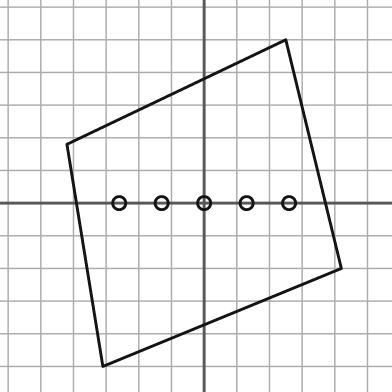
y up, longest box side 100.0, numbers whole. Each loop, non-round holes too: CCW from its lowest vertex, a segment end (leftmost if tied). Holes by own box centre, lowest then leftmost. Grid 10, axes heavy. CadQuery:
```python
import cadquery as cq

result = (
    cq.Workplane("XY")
    .moveTo(-31.0, -50.0)
    .lineTo(42.0, -20.0)
    .lineTo(25.0, 50.0)
    .lineTo(-42.0, 18.0)
    .close()
    .moveTo(-26.0, 0.0)
    .circle(2.0)
    .moveTo(-13.0, 0.0)
    .circle(2.0)
    .moveTo(0.0, 0.0)
    .circle(2.0)
    .moveTo(13.0, 0.0)
    .circle(2.0)
    .moveTo(26.0, 0.0)
    .circle(2.0)
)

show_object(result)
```